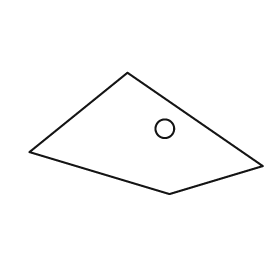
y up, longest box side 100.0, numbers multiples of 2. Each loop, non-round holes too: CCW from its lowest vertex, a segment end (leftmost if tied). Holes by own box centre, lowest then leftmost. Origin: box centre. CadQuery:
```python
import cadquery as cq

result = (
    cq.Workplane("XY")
    .moveTo(10.0, -26.0)
    .lineTo(50.0, -14.0)
    .lineTo(-8.0, 26.0)
    .lineTo(-50.0, -8.0)
    .close()
    .moveTo(8.0, 2.0)
    .circle(4.0)
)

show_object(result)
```